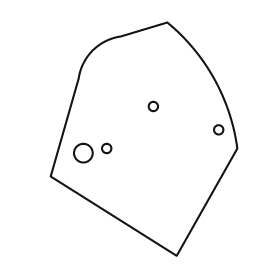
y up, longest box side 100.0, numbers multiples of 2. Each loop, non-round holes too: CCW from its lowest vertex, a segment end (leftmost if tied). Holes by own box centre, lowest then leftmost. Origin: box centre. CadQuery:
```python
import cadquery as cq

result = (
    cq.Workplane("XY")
    .moveTo(14.0, -50.0)
    .lineTo(40.0, -4.0)
    .threePointArc((30.0, 26.0), (10.0, 50.0))
    .lineTo(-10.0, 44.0)
    .threePointArc((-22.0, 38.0), (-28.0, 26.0))
    .lineTo(-40.0, -16.0)
    .close()
    .moveTo(-26.0, -6.0)
    .circle(4.0)
    .moveTo(-16.0, -4.0)
    .circle(2.0)
    .moveTo(32.0, 4.0)
    .circle(2.0)
    .moveTo(4.0, 14.0)
    .circle(2.0)
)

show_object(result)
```